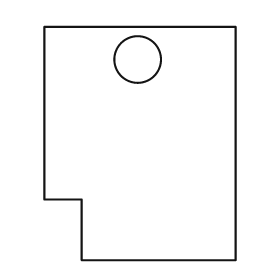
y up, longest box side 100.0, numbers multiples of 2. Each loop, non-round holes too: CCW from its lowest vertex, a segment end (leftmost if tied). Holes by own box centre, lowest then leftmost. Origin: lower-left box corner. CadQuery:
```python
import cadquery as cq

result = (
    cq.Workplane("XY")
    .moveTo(16.0, 0.0)
    .lineTo(82.0, 0.0)
    .lineTo(82.0, 100.0)
    .lineTo(0.0, 100.0)
    .lineTo(0.0, 26.0)
    .lineTo(16.0, 26.0)
    .close()
    .moveTo(40.0, 86.0)
    .circle(10.0)
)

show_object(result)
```